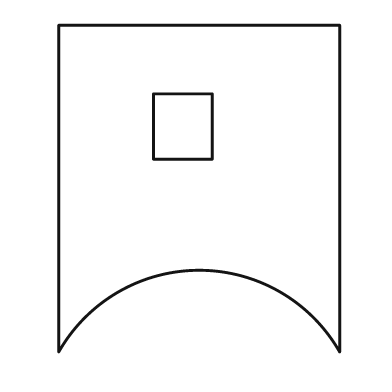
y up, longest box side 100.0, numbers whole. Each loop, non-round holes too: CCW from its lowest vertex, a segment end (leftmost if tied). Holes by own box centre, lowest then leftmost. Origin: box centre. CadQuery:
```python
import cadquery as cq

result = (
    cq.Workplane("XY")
    .moveTo(-43.0, -50.0)
    .threePointArc((0.0, -25.0), (43.0, -50.0))
    .lineTo(43.0, 50.0)
    .lineTo(-43.0, 50.0)
    .close()
    .moveTo(-14.0, 9.0)
    .lineTo(4.0, 9.0)
    .lineTo(4.0, 29.0)
    .lineTo(-14.0, 29.0)
    .close()
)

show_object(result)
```